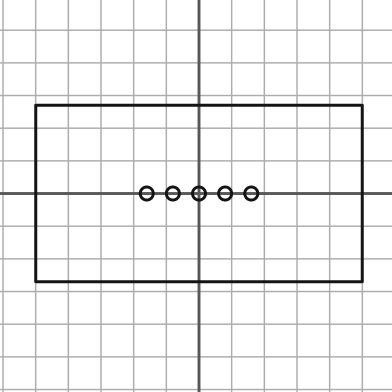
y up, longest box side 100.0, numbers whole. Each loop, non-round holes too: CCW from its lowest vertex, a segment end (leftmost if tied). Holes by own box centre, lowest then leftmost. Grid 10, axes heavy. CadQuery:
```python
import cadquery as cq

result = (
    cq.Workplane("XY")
    .moveTo(-50.0, -27.0)
    .lineTo(50.0, -27.0)
    .lineTo(50.0, 27.0)
    .lineTo(-50.0, 27.0)
    .close()
    .moveTo(-16.0, 0.0)
    .circle(2.0)
    .moveTo(-8.0, 0.0)
    .circle(2.0)
    .moveTo(0.0, 0.0)
    .circle(2.0)
    .moveTo(8.0, 0.0)
    .circle(2.0)
    .moveTo(16.0, 0.0)
    .circle(2.0)
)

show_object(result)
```